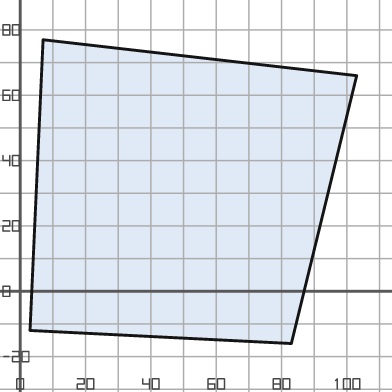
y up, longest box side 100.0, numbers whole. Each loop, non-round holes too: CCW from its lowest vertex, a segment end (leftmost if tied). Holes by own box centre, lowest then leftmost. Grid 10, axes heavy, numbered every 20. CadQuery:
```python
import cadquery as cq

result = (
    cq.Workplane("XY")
    .moveTo(83.0, -16.0)
    .lineTo(103.0, 66.0)
    .lineTo(7.0, 77.0)
    .lineTo(3.0, -12.0)
    .close()
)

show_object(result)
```